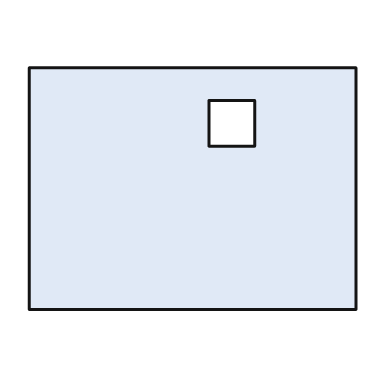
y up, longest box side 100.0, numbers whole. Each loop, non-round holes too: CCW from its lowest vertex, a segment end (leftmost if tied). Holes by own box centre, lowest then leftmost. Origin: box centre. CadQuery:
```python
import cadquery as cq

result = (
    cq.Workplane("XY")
    .moveTo(-50.0, -37.0)
    .lineTo(50.0, -37.0)
    .lineTo(50.0, 37.0)
    .lineTo(-50.0, 37.0)
    .close()
    .moveTo(5.0, 13.0)
    .lineTo(19.0, 13.0)
    .lineTo(19.0, 27.0)
    .lineTo(5.0, 27.0)
    .close()
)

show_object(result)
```